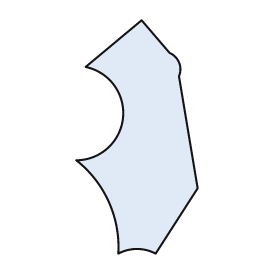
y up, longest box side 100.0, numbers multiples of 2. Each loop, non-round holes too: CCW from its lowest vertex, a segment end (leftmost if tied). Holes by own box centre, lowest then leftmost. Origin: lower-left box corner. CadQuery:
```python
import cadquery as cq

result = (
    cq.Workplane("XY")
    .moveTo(18.0, 0.0)
    .threePointArc((26.0, 2.0), (34.0, 0.0))
    .lineTo(52.0, 28.0)
    .lineTo(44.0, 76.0)
    .threePointArc((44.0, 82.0), (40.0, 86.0))
    .lineTo(28.0, 100.0)
    .lineTo(4.0, 80.0)
    .threePointArc((20.0, 58.0), (0.0, 40.0))
    .threePointArc((14.0, 22.0), (18.0, 0.0))
    .close()
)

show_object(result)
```